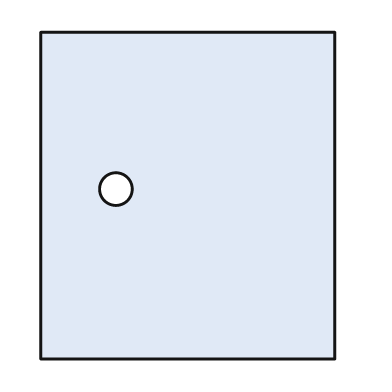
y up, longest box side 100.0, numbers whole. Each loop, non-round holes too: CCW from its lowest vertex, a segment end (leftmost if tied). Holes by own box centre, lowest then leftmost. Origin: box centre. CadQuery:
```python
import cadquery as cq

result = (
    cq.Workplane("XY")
    .moveTo(-45.0, -50.0)
    .lineTo(45.0, -50.0)
    .lineTo(45.0, 50.0)
    .lineTo(-45.0, 50.0)
    .close()
    .moveTo(-22.0, 2.0)
    .circle(5.0)
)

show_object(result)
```